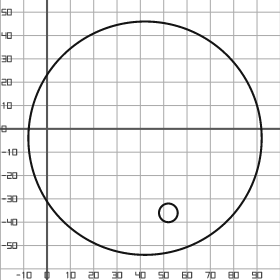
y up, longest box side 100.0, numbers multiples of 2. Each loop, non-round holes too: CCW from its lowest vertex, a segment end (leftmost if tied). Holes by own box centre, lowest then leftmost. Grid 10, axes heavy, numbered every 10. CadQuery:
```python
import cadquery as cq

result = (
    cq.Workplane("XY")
    .moveTo(42.0, -4.0)
    .circle(50.0)
    .moveTo(52.0, -36.0)
    .circle(4.0)
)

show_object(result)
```